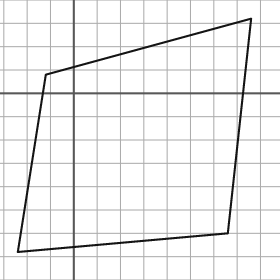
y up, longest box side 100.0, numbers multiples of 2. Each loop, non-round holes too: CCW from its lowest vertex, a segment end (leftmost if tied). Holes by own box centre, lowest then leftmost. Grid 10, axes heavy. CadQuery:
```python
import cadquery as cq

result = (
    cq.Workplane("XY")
    .moveTo(-24.0, -68.0)
    .lineTo(66.0, -60.0)
    .lineTo(76.0, 32.0)
    .lineTo(-12.0, 8.0)
    .close()
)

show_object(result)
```